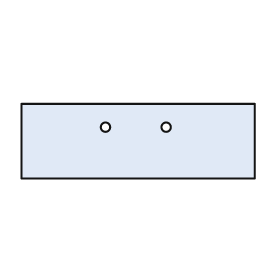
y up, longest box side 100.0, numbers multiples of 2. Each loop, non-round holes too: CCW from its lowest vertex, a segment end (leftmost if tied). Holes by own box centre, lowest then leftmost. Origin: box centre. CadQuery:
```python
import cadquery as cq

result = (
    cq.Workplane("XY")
    .moveTo(-50.0, -16.0)
    .lineTo(50.0, -16.0)
    .lineTo(50.0, 16.0)
    .lineTo(-50.0, 16.0)
    .close()
    .moveTo(-14.0, 6.0)
    .circle(2.0)
    .moveTo(12.0, 6.0)
    .circle(2.0)
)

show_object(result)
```